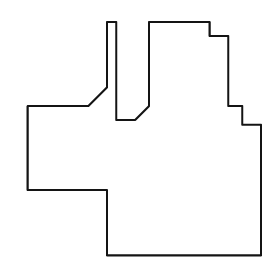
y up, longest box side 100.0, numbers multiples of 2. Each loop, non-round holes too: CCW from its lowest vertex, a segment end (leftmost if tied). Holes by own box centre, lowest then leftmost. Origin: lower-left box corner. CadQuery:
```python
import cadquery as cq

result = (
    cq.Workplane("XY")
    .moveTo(34.0, 0.0)
    .lineTo(100.0, 0.0)
    .lineTo(100.0, 56.0)
    .lineTo(92.0, 56.0)
    .lineTo(92.0, 64.0)
    .lineTo(86.0, 64.0)
    .lineTo(86.0, 94.0)
    .lineTo(78.0, 94.0)
    .lineTo(78.0, 100.0)
    .lineTo(52.0, 100.0)
    .lineTo(52.0, 64.0)
    .lineTo(46.0, 58.0)
    .lineTo(38.0, 58.0)
    .lineTo(38.0, 100.0)
    .lineTo(34.0, 100.0)
    .lineTo(34.0, 72.0)
    .lineTo(26.0, 64.0)
    .lineTo(0.0, 64.0)
    .lineTo(0.0, 28.0)
    .lineTo(34.0, 28.0)
    .close()
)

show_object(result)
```